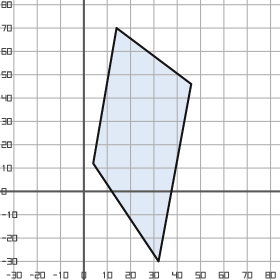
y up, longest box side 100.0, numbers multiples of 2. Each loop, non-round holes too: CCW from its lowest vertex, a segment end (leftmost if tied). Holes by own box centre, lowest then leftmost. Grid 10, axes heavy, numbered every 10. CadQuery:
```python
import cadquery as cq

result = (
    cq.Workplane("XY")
    .moveTo(32.0, -30.0)
    .lineTo(46.0, 46.0)
    .lineTo(14.0, 70.0)
    .lineTo(4.0, 12.0)
    .close()
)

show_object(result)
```